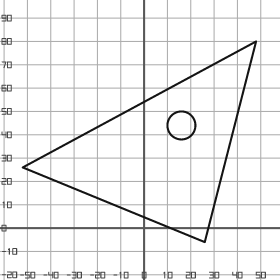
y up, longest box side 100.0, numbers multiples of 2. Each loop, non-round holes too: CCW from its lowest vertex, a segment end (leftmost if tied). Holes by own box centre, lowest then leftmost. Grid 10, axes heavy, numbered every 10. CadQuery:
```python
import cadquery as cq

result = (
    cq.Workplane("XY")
    .moveTo(26.0, -6.0)
    .lineTo(48.0, 80.0)
    .lineTo(-52.0, 26.0)
    .close()
    .moveTo(16.0, 44.0)
    .circle(6.0)
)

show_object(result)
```